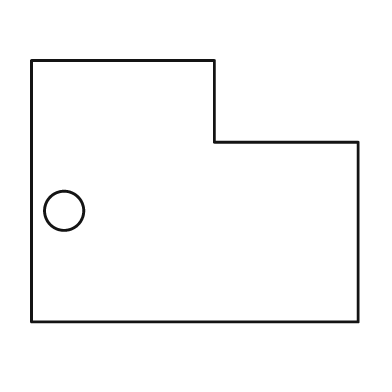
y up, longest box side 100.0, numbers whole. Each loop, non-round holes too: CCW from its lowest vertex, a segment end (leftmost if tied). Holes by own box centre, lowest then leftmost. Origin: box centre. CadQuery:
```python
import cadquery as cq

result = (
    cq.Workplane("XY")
    .moveTo(-50.0, -40.0)
    .lineTo(50.0, -40.0)
    .lineTo(50.0, 15.0)
    .lineTo(6.0, 15.0)
    .lineTo(6.0, 40.0)
    .lineTo(-50.0, 40.0)
    .close()
    .moveTo(-40.0, -6.0)
    .circle(6.0)
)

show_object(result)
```